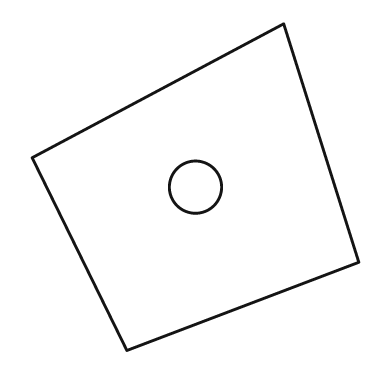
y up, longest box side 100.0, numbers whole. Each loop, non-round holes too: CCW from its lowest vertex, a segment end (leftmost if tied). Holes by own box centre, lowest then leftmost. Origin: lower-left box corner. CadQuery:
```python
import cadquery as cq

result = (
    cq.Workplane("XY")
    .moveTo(29.0, 0.0)
    .lineTo(100.0, 27.0)
    .lineTo(77.0, 100.0)
    .lineTo(0.0, 59.0)
    .close()
    .moveTo(50.0, 50.0)
    .circle(8.0)
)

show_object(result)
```